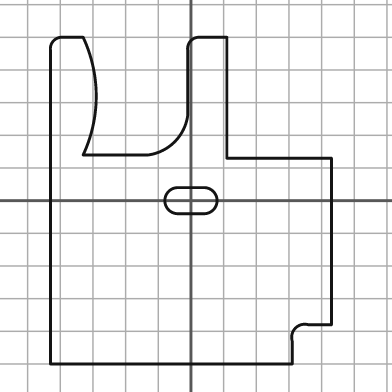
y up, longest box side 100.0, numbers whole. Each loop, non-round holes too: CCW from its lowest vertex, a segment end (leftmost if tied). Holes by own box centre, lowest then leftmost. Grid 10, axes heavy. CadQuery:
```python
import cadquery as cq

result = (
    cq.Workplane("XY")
    .moveTo(-43.0, -50.0)
    .lineTo(31.0, -50.0)
    .lineTo(31.0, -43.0)
    .threePointArc((32.0, -39.0), (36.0, -38.0))
    .lineTo(43.0, -38.0)
    .lineTo(43.0, 13.0)
    .lineTo(11.0, 13.0)
    .lineTo(11.0, 50.0)
    .lineTo(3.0, 50.0)
    .threePointArc((0.0, 49.0), (-1.0, 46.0))
    .lineTo(-1.0, 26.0)
    .threePointArc((-5.0, 18.0), (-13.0, 14.0))
    .lineTo(-33.0, 14.0)
    .threePointArc((-29.0, 32.0), (-33.0, 50.0))
    .lineTo(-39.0, 50.0)
    .threePointArc((-42.0, 49.0), (-43.0, 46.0))
    .close()
    .moveTo(-4.0, -4.0)
    .lineTo(4.0, -4.0)
    .threePointArc((8.0, 0.0), (4.0, 4.0))
    .lineTo(-4.0, 4.0)
    .threePointArc((-8.0, 0.0), (-4.0, -4.0))
    .close()
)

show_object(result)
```